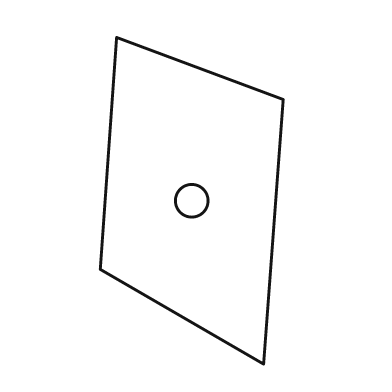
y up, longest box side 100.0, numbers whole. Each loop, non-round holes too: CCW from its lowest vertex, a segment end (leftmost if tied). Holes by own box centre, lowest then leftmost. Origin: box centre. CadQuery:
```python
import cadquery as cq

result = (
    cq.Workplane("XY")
    .moveTo(22.0, -50.0)
    .lineTo(28.0, 31.0)
    .lineTo(-23.0, 50.0)
    .lineTo(-28.0, -21.0)
    .close()
    .moveTo(0.0, 0.0)
    .circle(5.0)
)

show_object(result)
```